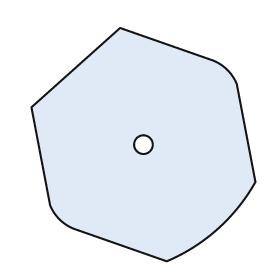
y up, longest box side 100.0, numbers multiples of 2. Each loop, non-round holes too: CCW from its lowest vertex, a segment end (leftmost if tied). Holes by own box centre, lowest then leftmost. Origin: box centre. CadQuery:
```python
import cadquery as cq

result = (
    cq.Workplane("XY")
    .moveTo(10.0, -50.0)
    .threePointArc((32.0, -36.0), (48.0, -16.0))
    .lineTo(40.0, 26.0)
    .threePointArc((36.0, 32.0), (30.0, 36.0))
    .lineTo(-10.0, 50.0)
    .lineTo(-48.0, 16.0)
    .lineTo(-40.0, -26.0)
    .threePointArc((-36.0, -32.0), (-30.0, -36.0))
    .close()
    .moveTo(0.0, 0.0)
    .circle(4.0)
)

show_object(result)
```